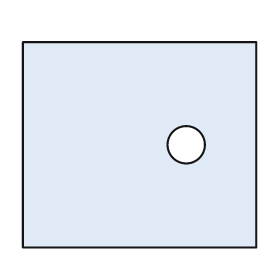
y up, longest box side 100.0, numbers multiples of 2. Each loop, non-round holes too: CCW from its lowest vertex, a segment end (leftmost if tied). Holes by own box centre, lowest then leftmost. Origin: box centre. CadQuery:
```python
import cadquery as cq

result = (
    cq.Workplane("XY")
    .moveTo(-50.0, -44.0)
    .lineTo(50.0, -44.0)
    .lineTo(50.0, 44.0)
    .lineTo(-50.0, 44.0)
    .close()
    .moveTo(20.0, 0.0)
    .circle(8.0)
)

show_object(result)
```